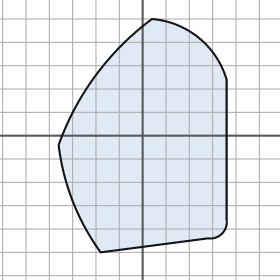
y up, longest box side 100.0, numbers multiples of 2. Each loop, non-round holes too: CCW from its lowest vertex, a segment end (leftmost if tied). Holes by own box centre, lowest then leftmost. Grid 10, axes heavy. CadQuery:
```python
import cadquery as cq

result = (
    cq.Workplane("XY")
    .moveTo(-18.0, -50.0)
    .lineTo(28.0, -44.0)
    .threePointArc((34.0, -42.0), (36.0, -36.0))
    .lineTo(36.0, 24.0)
    .threePointArc((24.0, 42.0), (4.0, 50.0))
    .threePointArc((-20.0, 26.0), (-36.0, -4.0))
    .threePointArc((-30.0, -28.0), (-18.0, -50.0))
    .close()
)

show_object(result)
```